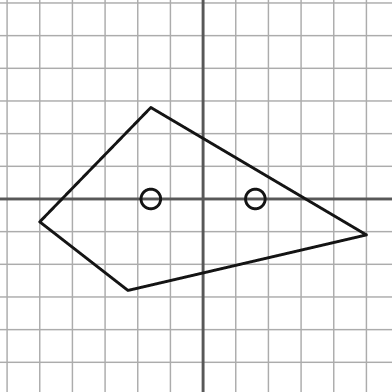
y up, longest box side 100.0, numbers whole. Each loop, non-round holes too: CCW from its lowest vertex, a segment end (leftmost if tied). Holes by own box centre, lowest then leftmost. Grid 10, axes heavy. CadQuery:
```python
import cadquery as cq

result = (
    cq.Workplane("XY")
    .moveTo(-23.0, -28.0)
    .lineTo(50.0, -11.0)
    .lineTo(-16.0, 28.0)
    .lineTo(-50.0, -7.0)
    .close()
    .moveTo(-16.0, 0.0)
    .circle(3.0)
    .moveTo(16.0, 0.0)
    .circle(3.0)
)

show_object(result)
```